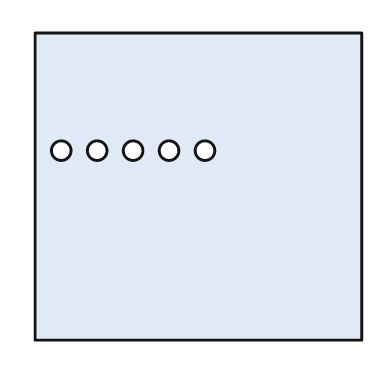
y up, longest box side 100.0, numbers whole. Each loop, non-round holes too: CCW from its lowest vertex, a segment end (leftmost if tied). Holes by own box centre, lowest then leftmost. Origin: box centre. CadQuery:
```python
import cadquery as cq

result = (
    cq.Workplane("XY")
    .moveTo(-50.0, -47.0)
    .lineTo(50.0, -47.0)
    .lineTo(50.0, 47.0)
    .lineTo(-50.0, 47.0)
    .close()
    .moveTo(-42.0, 11.0)
    .circle(3.0)
    .moveTo(-31.0, 11.0)
    .circle(3.0)
    .moveTo(-20.0, 11.0)
    .circle(3.0)
    .moveTo(-9.0, 11.0)
    .circle(3.0)
    .moveTo(2.0, 11.0)
    .circle(3.0)
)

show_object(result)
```